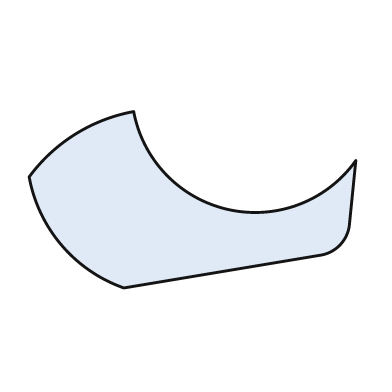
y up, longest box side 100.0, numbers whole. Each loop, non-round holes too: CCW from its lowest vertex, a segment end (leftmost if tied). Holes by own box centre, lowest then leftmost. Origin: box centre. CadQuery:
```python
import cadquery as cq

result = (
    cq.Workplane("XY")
    .moveTo(-21.0, -27.0)
    .lineTo(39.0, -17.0)
    .threePointArc((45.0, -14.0), (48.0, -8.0))
    .lineTo(50.0, 12.0)
    .threePointArc((11.0, -3.0), (-18.0, 27.0))
    .threePointArc((-36.0, 20.0), (-50.0, 7.0))
    .threePointArc((-40.0, -14.0), (-21.0, -27.0))
    .close()
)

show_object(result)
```